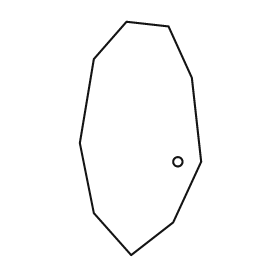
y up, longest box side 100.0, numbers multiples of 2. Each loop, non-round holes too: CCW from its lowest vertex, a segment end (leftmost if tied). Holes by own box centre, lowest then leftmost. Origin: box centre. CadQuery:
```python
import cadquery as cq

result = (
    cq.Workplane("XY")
    .moveTo(-4.0, -50.0)
    .lineTo(14.0, -36.0)
    .lineTo(26.0, -10.0)
    .lineTo(22.0, 26.0)
    .lineTo(12.0, 48.0)
    .lineTo(-6.0, 50.0)
    .lineTo(-20.0, 34.0)
    .lineTo(-26.0, -2.0)
    .lineTo(-20.0, -32.0)
    .close()
    .moveTo(16.0, -10.0)
    .circle(2.0)
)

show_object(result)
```